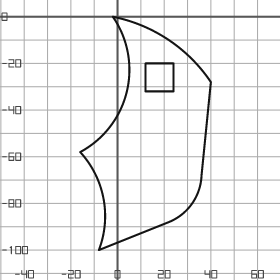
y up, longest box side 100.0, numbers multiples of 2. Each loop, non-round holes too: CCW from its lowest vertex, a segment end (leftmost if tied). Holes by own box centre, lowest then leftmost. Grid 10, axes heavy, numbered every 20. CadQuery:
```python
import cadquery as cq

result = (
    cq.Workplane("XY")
    .moveTo(-8.0, -100.0)
    .lineTo(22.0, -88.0)
    .threePointArc((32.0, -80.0), (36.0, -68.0))
    .lineTo(40.0, -28.0)
    .threePointArc((22.0, -10.0), (-2.0, 0.0))
    .threePointArc((4.0, -32.0), (-16.0, -58.0))
    .threePointArc((-6.0, -78.0), (-8.0, -100.0))
    .close()
    .moveTo(12.0, -32.0)
    .lineTo(24.0, -32.0)
    .lineTo(24.0, -20.0)
    .lineTo(12.0, -20.0)
    .close()
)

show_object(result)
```